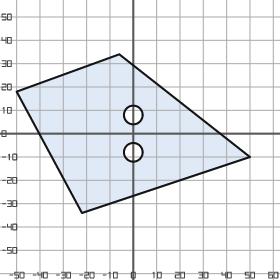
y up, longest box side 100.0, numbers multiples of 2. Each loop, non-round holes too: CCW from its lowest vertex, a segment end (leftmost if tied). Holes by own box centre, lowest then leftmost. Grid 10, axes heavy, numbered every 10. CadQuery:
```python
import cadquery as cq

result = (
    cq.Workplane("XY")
    .moveTo(-22.0, -34.0)
    .lineTo(50.0, -10.0)
    .lineTo(-6.0, 34.0)
    .lineTo(-50.0, 18.0)
    .close()
    .moveTo(0.0, -8.0)
    .circle(4.0)
    .moveTo(0.0, 8.0)
    .circle(4.0)
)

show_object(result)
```